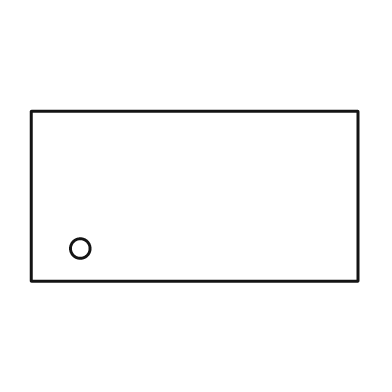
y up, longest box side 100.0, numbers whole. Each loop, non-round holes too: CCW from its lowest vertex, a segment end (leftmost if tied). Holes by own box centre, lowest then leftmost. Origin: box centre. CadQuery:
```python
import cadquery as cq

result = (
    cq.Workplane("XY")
    .moveTo(-50.0, -26.0)
    .lineTo(50.0, -26.0)
    .lineTo(50.0, 26.0)
    .lineTo(-50.0, 26.0)
    .close()
    .moveTo(-35.0, -16.0)
    .circle(3.0)
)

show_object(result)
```